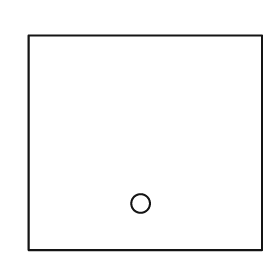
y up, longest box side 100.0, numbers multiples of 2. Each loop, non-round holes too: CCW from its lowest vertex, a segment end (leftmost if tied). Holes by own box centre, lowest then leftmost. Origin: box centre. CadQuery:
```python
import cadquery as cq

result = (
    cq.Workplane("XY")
    .moveTo(-50.0, -46.0)
    .lineTo(50.0, -46.0)
    .lineTo(50.0, 46.0)
    .lineTo(-50.0, 46.0)
    .close()
    .moveTo(-2.0, -26.0)
    .circle(4.0)
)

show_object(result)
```